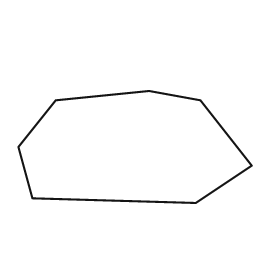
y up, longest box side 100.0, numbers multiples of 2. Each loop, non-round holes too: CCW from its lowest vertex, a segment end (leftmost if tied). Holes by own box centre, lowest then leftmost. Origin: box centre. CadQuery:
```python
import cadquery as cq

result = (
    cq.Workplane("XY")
    .moveTo(26.0, -24.0)
    .lineTo(50.0, -8.0)
    .lineTo(28.0, 20.0)
    .lineTo(6.0, 24.0)
    .lineTo(-34.0, 20.0)
    .lineTo(-50.0, 0.0)
    .lineTo(-44.0, -22.0)
    .close()
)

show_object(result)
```